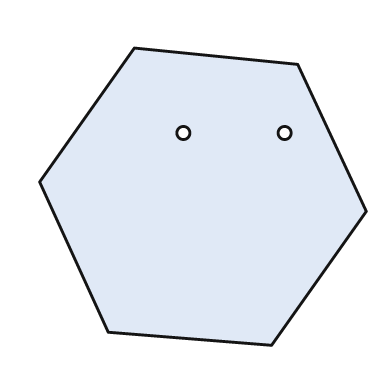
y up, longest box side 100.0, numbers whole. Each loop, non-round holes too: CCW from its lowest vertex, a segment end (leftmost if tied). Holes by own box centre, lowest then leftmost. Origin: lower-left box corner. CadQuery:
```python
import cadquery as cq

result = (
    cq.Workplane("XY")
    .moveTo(71.0, 0.0)
    .lineTo(100.0, 41.0)
    .lineTo(79.0, 86.0)
    .lineTo(29.0, 91.0)
    .lineTo(0.0, 50.0)
    .lineTo(21.0, 4.0)
    .close()
    .moveTo(44.0, 65.0)
    .circle(2.0)
    .moveTo(75.0, 65.0)
    .circle(2.0)
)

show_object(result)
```